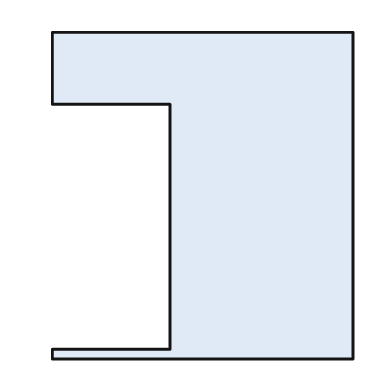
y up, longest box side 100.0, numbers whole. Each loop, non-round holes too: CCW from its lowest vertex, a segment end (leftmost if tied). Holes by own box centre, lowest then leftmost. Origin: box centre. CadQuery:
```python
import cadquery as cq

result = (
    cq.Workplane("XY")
    .moveTo(-46.0, -50.0)
    .lineTo(46.0, -50.0)
    .lineTo(46.0, 50.0)
    .lineTo(-46.0, 50.0)
    .lineTo(-46.0, 28.0)
    .lineTo(-10.0, 28.0)
    .lineTo(-10.0, -47.0)
    .lineTo(-46.0, -47.0)
    .close()
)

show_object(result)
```